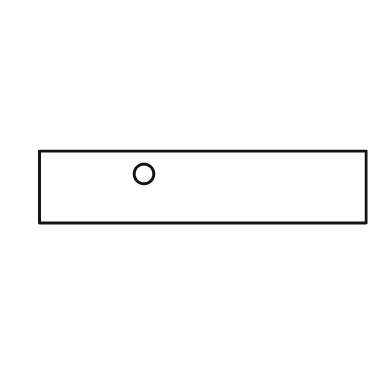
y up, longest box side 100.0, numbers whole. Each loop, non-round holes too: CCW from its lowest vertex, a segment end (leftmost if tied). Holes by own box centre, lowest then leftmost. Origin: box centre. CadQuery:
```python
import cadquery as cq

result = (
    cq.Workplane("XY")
    .moveTo(-50.0, -11.0)
    .lineTo(50.0, -11.0)
    .lineTo(50.0, 11.0)
    .lineTo(-50.0, 11.0)
    .close()
    .moveTo(-18.0, 4.0)
    .circle(3.0)
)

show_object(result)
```